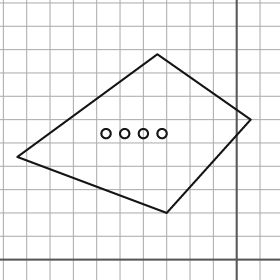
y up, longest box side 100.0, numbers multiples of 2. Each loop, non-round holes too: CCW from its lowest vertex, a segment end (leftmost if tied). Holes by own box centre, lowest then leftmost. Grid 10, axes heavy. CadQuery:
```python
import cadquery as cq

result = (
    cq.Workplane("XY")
    .moveTo(-30.0, 20.0)
    .lineTo(6.0, 60.0)
    .lineTo(-34.0, 88.0)
    .lineTo(-94.0, 44.0)
    .close()
    .moveTo(-56.0, 54.0)
    .circle(2.0)
    .moveTo(-48.0, 54.0)
    .circle(2.0)
    .moveTo(-40.0, 54.0)
    .circle(2.0)
    .moveTo(-32.0, 54.0)
    .circle(2.0)
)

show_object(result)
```